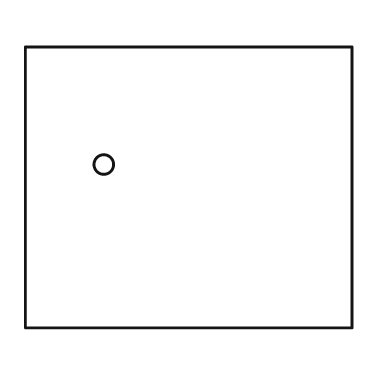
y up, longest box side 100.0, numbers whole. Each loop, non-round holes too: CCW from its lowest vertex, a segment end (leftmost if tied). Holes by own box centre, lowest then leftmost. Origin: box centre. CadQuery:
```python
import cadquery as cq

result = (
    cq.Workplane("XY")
    .moveTo(-50.0, -43.0)
    .lineTo(50.0, -43.0)
    .lineTo(50.0, 43.0)
    .lineTo(-50.0, 43.0)
    .close()
    .moveTo(-26.0, 7.0)
    .circle(3.0)
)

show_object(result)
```